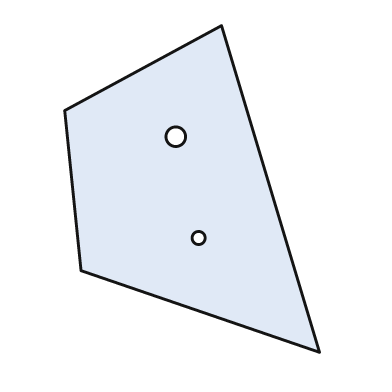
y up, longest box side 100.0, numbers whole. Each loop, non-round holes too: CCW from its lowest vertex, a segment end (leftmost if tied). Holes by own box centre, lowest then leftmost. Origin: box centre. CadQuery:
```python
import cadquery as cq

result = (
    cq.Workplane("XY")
    .moveTo(39.0, -50.0)
    .lineTo(9.0, 50.0)
    .lineTo(-39.0, 24.0)
    .lineTo(-34.0, -25.0)
    .close()
    .moveTo(2.0, -15.0)
    .circle(2.0)
    .moveTo(-5.0, 16.0)
    .circle(3.0)
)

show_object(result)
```